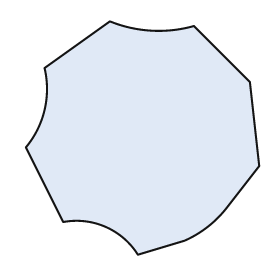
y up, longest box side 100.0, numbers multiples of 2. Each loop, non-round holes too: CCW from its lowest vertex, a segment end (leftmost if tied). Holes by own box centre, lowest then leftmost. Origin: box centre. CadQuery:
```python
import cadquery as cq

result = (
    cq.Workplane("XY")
    .moveTo(-2.0, -50.0)
    .lineTo(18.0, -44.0)
    .threePointArc((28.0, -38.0), (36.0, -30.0))
    .lineTo(50.0, -12.0)
    .lineTo(46.0, 24.0)
    .lineTo(22.0, 48.0)
    .threePointArc((4.0, 46.0), (-14.0, 50.0))
    .lineTo(-42.0, 30.0)
    .threePointArc((-42.0, 12.0), (-50.0, -4.0))
    .lineTo(-34.0, -36.0)
    .threePointArc((-16.0, -38.0), (-2.0, -50.0))
    .close()
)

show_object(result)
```